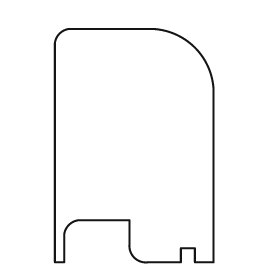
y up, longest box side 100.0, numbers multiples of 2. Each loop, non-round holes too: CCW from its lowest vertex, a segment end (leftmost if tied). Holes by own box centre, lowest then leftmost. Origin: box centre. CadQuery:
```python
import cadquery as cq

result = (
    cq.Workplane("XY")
    .moveTo(-34.0, -50.0)
    .lineTo(-30.0, -50.0)
    .lineTo(-30.0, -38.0)
    .threePointArc((-28.0, -34.0), (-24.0, -32.0))
    .lineTo(-2.0, -32.0)
    .lineTo(-2.0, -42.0)
    .threePointArc((0.0, -48.0), (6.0, -50.0))
    .lineTo(20.0, -50.0)
    .lineTo(20.0, -44.0)
    .lineTo(26.0, -44.0)
    .lineTo(26.0, -50.0)
    .lineTo(34.0, -50.0)
    .lineTo(34.0, 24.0)
    .threePointArc((26.0, 42.0), (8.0, 50.0))
    .lineTo(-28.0, 50.0)
    .threePointArc((-32.0, 48.0), (-34.0, 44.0))
    .close()
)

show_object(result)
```